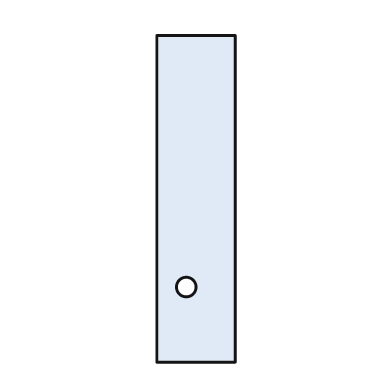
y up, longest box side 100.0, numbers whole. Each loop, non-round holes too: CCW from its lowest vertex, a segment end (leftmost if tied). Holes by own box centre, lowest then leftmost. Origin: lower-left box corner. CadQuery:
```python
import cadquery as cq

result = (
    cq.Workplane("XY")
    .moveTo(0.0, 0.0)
    .lineTo(24.0, 0.0)
    .lineTo(24.0, 100.0)
    .lineTo(0.0, 100.0)
    .close()
    .moveTo(9.0, 23.0)
    .circle(3.0)
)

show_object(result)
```